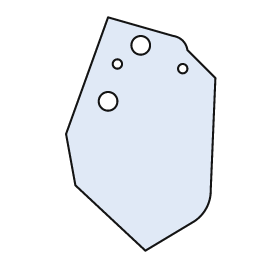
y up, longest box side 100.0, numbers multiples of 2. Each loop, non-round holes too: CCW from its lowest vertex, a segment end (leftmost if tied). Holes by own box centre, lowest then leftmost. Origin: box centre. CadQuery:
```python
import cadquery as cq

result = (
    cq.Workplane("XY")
    .moveTo(2.0, -50.0)
    .lineTo(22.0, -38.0)
    .threePointArc((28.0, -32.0), (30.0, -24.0))
    .lineTo(32.0, 24.0)
    .lineTo(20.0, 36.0)
    .threePointArc((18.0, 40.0), (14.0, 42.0))
    .lineTo(-14.0, 50.0)
    .lineTo(-32.0, 0.0)
    .lineTo(-28.0, -22.0)
    .close()
    .moveTo(-14.0, 14.0)
    .circle(4.0)
    .moveTo(18.0, 28.0)
    .circle(2.0)
    .moveTo(-10.0, 30.0)
    .circle(2.0)
    .moveTo(0.0, 38.0)
    .circle(4.0)
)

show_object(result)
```